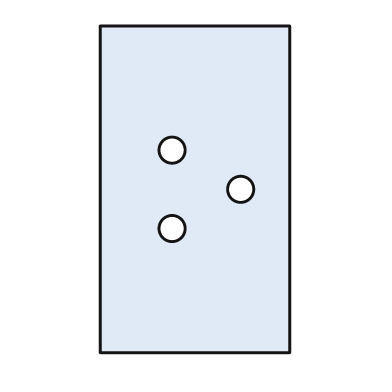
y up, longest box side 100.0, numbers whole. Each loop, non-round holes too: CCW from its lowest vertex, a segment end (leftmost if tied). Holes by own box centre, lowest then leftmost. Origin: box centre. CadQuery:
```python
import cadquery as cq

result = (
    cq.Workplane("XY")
    .moveTo(-29.0, -50.0)
    .lineTo(29.0, -50.0)
    .lineTo(29.0, 50.0)
    .lineTo(-29.0, 50.0)
    .close()
    .moveTo(-7.0, -12.0)
    .circle(4.0)
    .moveTo(14.0, 0.0)
    .circle(4.0)
    .moveTo(-7.0, 12.0)
    .circle(4.0)
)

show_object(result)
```